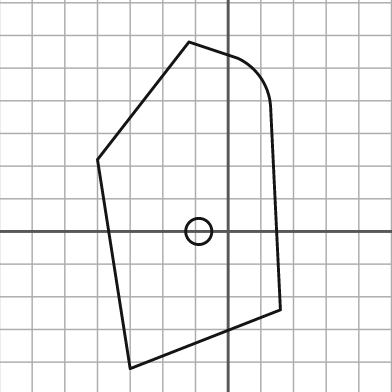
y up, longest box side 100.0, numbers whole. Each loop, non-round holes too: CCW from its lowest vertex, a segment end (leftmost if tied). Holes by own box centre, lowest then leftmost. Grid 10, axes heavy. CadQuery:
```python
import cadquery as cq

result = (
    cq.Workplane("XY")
    .moveTo(-30.0, -42.0)
    .lineTo(16.0, -24.0)
    .lineTo(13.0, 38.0)
    .threePointArc((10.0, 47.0), (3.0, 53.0))
    .lineTo(-12.0, 58.0)
    .lineTo(-40.0, 22.0)
    .close()
    .moveTo(-9.0, 0.0)
    .circle(4.0)
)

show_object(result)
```